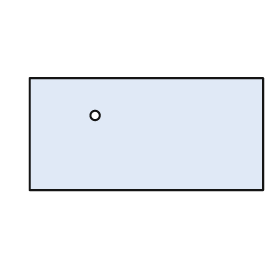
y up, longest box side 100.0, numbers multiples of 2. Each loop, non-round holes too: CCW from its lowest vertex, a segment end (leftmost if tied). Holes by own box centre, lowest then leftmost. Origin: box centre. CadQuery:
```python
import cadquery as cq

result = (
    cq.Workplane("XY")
    .moveTo(-50.0, -24.0)
    .lineTo(50.0, -24.0)
    .lineTo(50.0, 24.0)
    .lineTo(-50.0, 24.0)
    .close()
    .moveTo(-22.0, 8.0)
    .circle(2.0)
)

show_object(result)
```